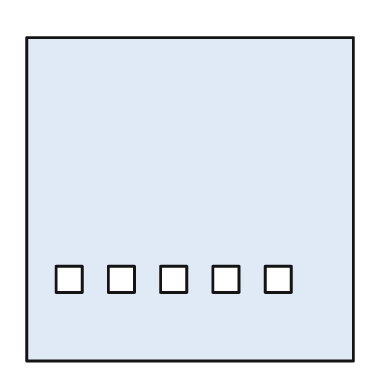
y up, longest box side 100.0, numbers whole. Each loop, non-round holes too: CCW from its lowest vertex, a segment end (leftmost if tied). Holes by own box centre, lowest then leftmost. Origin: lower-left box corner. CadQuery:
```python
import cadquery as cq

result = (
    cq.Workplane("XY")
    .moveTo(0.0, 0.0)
    .lineTo(100.0, 0.0)
    .lineTo(100.0, 99.0)
    .lineTo(0.0, 99.0)
    .close()
    .moveTo(9.0, 21.0)
    .lineTo(17.0, 21.0)
    .lineTo(17.0, 29.0)
    .lineTo(9.0, 29.0)
    .close()
    .moveTo(25.0, 21.0)
    .lineTo(33.0, 21.0)
    .lineTo(33.0, 29.0)
    .lineTo(25.0, 29.0)
    .close()
    .moveTo(41.0, 21.0)
    .lineTo(49.0, 21.0)
    .lineTo(49.0, 29.0)
    .lineTo(41.0, 29.0)
    .close()
    .moveTo(57.0, 21.0)
    .lineTo(65.0, 21.0)
    .lineTo(65.0, 29.0)
    .lineTo(57.0, 29.0)
    .close()
    .moveTo(73.0, 21.0)
    .lineTo(81.0, 21.0)
    .lineTo(81.0, 29.0)
    .lineTo(73.0, 29.0)
    .close()
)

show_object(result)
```